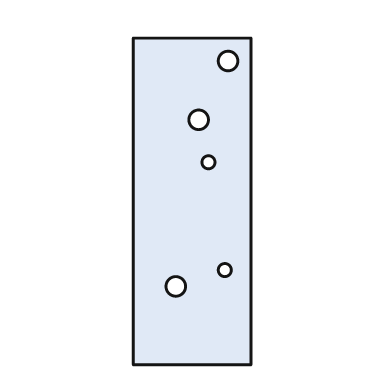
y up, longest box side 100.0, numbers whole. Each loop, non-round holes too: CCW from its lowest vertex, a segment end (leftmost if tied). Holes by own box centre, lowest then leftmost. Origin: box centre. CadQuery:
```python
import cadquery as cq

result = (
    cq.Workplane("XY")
    .moveTo(-18.0, -50.0)
    .lineTo(18.0, -50.0)
    .lineTo(18.0, 50.0)
    .lineTo(-18.0, 50.0)
    .close()
    .moveTo(-5.0, -26.0)
    .circle(3.0)
    .moveTo(10.0, -21.0)
    .circle(2.0)
    .moveTo(5.0, 12.0)
    .circle(2.0)
    .moveTo(2.0, 25.0)
    .circle(3.0)
    .moveTo(11.0, 43.0)
    .circle(3.0)
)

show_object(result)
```